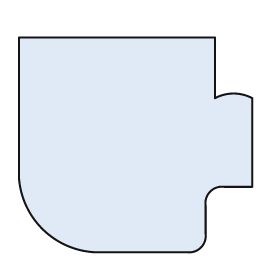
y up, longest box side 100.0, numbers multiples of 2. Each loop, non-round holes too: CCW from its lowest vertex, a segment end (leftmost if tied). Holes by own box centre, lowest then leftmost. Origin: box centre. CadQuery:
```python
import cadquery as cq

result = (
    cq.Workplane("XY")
    .moveTo(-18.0, -46.0)
    .lineTo(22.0, -46.0)
    .threePointArc((28.0, -44.0), (30.0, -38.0))
    .lineTo(30.0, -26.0)
    .threePointArc((32.0, -20.0), (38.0, -18.0))
    .lineTo(50.0, -18.0)
    .lineTo(50.0, 20.0)
    .threePointArc((42.0, 22.0), (34.0, 20.0))
    .lineTo(34.0, 46.0)
    .lineTo(-50.0, 46.0)
    .lineTo(-50.0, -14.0)
    .threePointArc((-40.0, -36.0), (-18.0, -46.0))
    .close()
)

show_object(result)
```